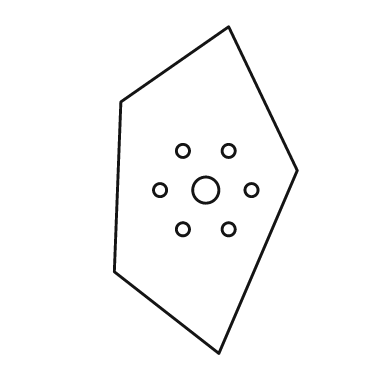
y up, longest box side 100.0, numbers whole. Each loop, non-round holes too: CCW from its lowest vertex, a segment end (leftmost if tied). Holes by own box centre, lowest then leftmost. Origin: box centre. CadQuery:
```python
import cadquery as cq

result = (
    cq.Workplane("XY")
    .moveTo(4.0, -50.0)
    .lineTo(28.0, 6.0)
    .lineTo(7.0, 50.0)
    .lineTo(-26.0, 27.0)
    .lineTo(-28.0, -25.0)
    .close()
    .moveTo(-7.0, -12.0)
    .circle(2.0)
    .moveTo(7.0, -12.0)
    .circle(2.0)
    .moveTo(-14.0, 0.0)
    .circle(2.0)
    .moveTo(0.0, 0.0)
    .circle(4.0)
    .moveTo(14.0, 0.0)
    .circle(2.0)
    .moveTo(-7.0, 12.0)
    .circle(2.0)
    .moveTo(7.0, 12.0)
    .circle(2.0)
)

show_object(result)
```